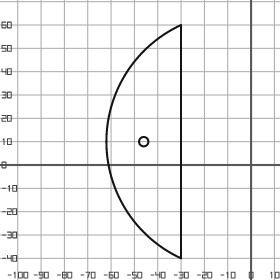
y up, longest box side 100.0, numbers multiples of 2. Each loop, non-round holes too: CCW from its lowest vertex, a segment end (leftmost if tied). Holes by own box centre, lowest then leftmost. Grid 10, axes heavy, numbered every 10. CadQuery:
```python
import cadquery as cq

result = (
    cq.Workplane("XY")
    .moveTo(-30.0, -40.0)
    .lineTo(-30.0, 60.0)
    .threePointArc((-62.0, 10.0), (-30.0, -40.0))
    .close()
    .moveTo(-46.0, 10.0)
    .circle(2.0)
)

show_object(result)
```